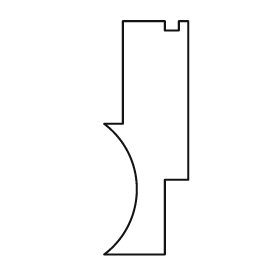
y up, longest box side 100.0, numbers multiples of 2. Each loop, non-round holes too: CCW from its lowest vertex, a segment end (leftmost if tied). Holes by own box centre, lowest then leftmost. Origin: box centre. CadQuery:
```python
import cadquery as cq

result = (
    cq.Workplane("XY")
    .moveTo(-18.0, -50.0)
    .lineTo(8.0, -50.0)
    .lineTo(8.0, -18.0)
    .lineTo(18.0, -18.0)
    .lineTo(18.0, 50.0)
    .lineTo(14.0, 50.0)
    .lineTo(14.0, 46.0)
    .lineTo(8.0, 46.0)
    .lineTo(8.0, 50.0)
    .lineTo(-10.0, 50.0)
    .lineTo(-10.0, 6.0)
    .lineTo(-18.0, 6.0)
    .threePointArc((-4.0, -22.0), (-18.0, -50.0))
    .close()
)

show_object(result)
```